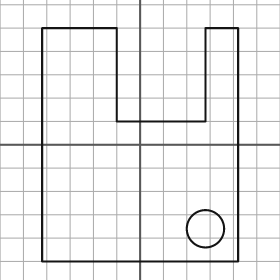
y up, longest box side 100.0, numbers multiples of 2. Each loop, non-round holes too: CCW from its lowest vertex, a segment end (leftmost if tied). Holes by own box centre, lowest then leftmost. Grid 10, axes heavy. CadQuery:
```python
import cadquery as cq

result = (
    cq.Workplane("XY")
    .moveTo(-42.0, -50.0)
    .lineTo(42.0, -50.0)
    .lineTo(42.0, 50.0)
    .lineTo(28.0, 50.0)
    .lineTo(28.0, 10.0)
    .lineTo(-10.0, 10.0)
    .lineTo(-10.0, 50.0)
    .lineTo(-42.0, 50.0)
    .close()
    .moveTo(28.0, -36.0)
    .circle(8.0)
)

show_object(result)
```